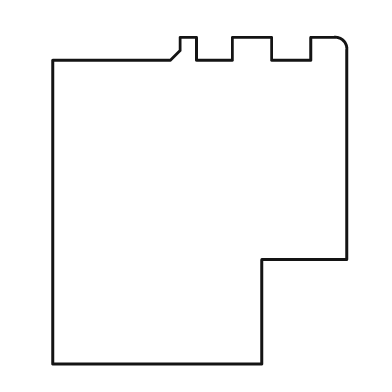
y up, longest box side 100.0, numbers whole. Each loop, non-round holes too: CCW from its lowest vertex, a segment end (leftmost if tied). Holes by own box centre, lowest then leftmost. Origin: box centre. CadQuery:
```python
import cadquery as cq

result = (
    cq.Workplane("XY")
    .moveTo(-45.0, -50.0)
    .lineTo(19.0, -50.0)
    .lineTo(19.0, -18.0)
    .lineTo(45.0, -18.0)
    .lineTo(45.0, 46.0)
    .threePointArc((44.0, 49.0), (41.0, 50.0))
    .lineTo(34.0, 50.0)
    .lineTo(34.0, 43.0)
    .lineTo(22.0, 43.0)
    .lineTo(22.0, 50.0)
    .lineTo(10.0, 50.0)
    .lineTo(10.0, 43.0)
    .lineTo(-1.0, 43.0)
    .lineTo(-1.0, 50.0)
    .lineTo(-6.0, 50.0)
    .lineTo(-6.0, 46.0)
    .lineTo(-9.0, 43.0)
    .lineTo(-45.0, 43.0)
    .close()
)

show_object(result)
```